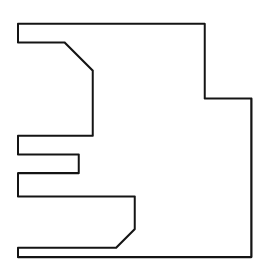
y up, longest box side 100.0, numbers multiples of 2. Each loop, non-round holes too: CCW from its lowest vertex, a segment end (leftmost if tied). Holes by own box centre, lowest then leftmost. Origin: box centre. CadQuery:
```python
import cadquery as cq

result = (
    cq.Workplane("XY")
    .moveTo(-50.0, -50.0)
    .lineTo(50.0, -50.0)
    .lineTo(50.0, 18.0)
    .lineTo(30.0, 18.0)
    .lineTo(30.0, 50.0)
    .lineTo(-50.0, 50.0)
    .lineTo(-50.0, 42.0)
    .lineTo(-30.0, 42.0)
    .lineTo(-18.0, 30.0)
    .lineTo(-18.0, 2.0)
    .lineTo(-50.0, 2.0)
    .lineTo(-50.0, -6.0)
    .lineTo(-24.0, -6.0)
    .lineTo(-24.0, -14.0)
    .lineTo(-50.0, -14.0)
    .lineTo(-50.0, -24.0)
    .lineTo(0.0, -24.0)
    .lineTo(0.0, -38.0)
    .lineTo(-8.0, -46.0)
    .lineTo(-50.0, -46.0)
    .close()
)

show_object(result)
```